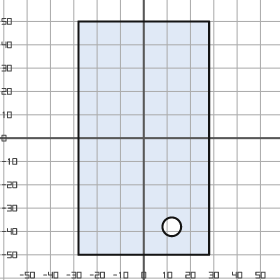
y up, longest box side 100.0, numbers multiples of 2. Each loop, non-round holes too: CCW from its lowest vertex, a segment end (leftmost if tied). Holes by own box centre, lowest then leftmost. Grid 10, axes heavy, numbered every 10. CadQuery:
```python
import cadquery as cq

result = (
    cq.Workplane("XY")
    .moveTo(-28.0, -50.0)
    .lineTo(28.0, -50.0)
    .lineTo(28.0, 50.0)
    .lineTo(-28.0, 50.0)
    .close()
    .moveTo(12.0, -38.0)
    .circle(4.0)
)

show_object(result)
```